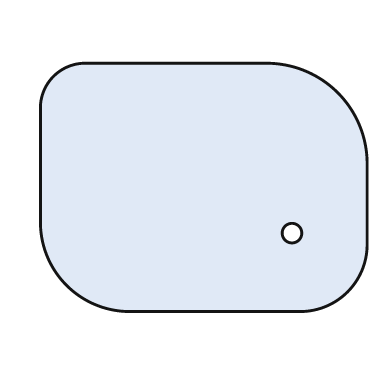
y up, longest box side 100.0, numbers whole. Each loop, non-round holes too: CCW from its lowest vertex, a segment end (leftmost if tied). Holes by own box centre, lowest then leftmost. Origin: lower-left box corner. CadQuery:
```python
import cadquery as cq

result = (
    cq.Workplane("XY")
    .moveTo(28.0, 0.0)
    .lineTo(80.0, 0.0)
    .threePointArc((94.0, 6.0), (100.0, 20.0))
    .lineTo(100.0, 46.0)
    .threePointArc((91.0, 67.0), (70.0, 76.0))
    .lineTo(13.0, 76.0)
    .threePointArc((4.0, 72.0), (0.0, 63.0))
    .lineTo(0.0, 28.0)
    .threePointArc((8.0, 8.0), (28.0, 0.0))
    .close()
    .moveTo(77.0, 24.0)
    .circle(3.0)
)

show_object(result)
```